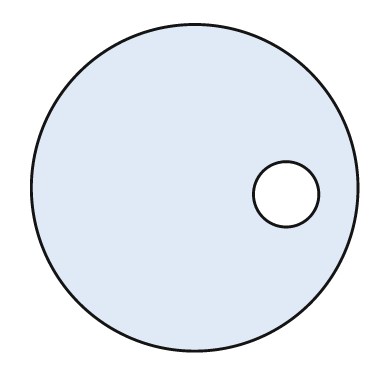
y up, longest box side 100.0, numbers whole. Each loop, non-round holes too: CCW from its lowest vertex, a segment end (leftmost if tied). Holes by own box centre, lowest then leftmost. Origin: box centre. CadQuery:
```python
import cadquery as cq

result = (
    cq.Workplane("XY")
    .moveTo(0.0, 0.0)
    .circle(50.0)
    .moveTo(28.0, -2.0)
    .circle(10.0)
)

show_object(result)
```